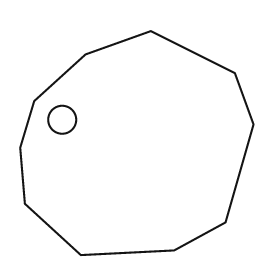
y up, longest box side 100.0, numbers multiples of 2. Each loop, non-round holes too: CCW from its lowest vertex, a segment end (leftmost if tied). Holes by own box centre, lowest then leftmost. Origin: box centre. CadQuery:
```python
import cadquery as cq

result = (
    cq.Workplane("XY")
    .moveTo(-24.0, -48.0)
    .lineTo(16.0, -46.0)
    .lineTo(38.0, -34.0)
    .lineTo(50.0, 8.0)
    .lineTo(42.0, 30.0)
    .lineTo(6.0, 48.0)
    .lineTo(-22.0, 38.0)
    .lineTo(-44.0, 18.0)
    .lineTo(-50.0, -2.0)
    .lineTo(-48.0, -26.0)
    .close()
    .moveTo(-32.0, 10.0)
    .circle(6.0)
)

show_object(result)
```